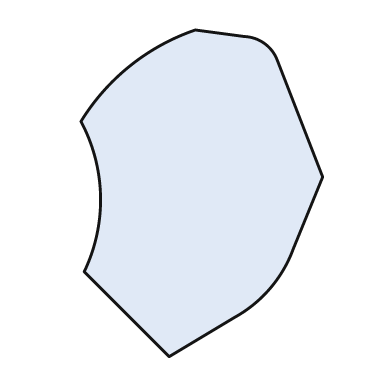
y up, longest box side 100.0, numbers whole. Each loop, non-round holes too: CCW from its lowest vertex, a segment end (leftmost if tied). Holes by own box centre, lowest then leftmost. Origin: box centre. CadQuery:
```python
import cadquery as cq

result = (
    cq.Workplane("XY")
    .moveTo(-10.0, -50.0)
    .lineTo(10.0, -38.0)
    .threePointArc((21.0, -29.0), (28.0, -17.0))
    .lineTo(37.0, 5.0)
    .lineTo(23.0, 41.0)
    .threePointArc((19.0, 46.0), (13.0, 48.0))
    .lineTo(-2.0, 50.0)
    .threePointArc((-22.0, 39.0), (-37.0, 22.0))
    .threePointArc((-31.0, -1.0), (-36.0, -24.0))
    .close()
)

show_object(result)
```